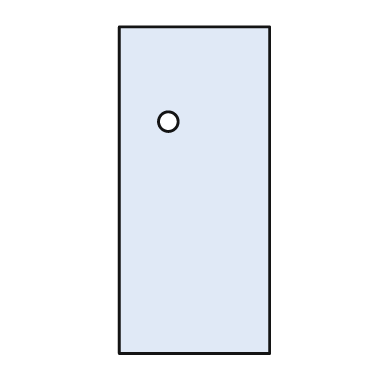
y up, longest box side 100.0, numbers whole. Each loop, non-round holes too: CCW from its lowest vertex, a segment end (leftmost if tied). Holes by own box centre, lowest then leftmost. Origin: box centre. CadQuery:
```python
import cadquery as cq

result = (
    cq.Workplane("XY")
    .moveTo(-23.0, -50.0)
    .lineTo(23.0, -50.0)
    .lineTo(23.0, 50.0)
    .lineTo(-23.0, 50.0)
    .close()
    .moveTo(-8.0, 21.0)
    .circle(3.0)
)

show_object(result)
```